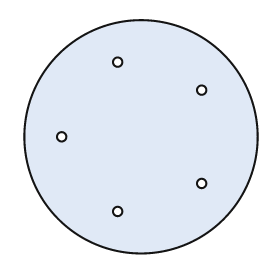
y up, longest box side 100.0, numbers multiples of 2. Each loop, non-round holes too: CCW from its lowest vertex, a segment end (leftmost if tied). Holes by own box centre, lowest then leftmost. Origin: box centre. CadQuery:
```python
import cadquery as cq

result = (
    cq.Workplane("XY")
    .moveTo(0.0, 0.0)
    .circle(50.0)
    .moveTo(-10.0, -32.0)
    .circle(2.0)
    .moveTo(26.0, -20.0)
    .circle(2.0)
    .moveTo(-34.0, 0.0)
    .circle(2.0)
    .moveTo(26.0, 20.0)
    .circle(2.0)
    .moveTo(-10.0, 32.0)
    .circle(2.0)
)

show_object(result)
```